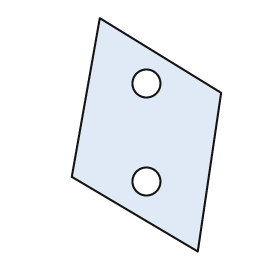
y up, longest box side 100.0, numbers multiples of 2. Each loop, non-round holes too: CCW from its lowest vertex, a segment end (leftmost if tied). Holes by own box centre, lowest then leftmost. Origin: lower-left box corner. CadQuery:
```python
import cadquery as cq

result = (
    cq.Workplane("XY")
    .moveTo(54.0, 0.0)
    .lineTo(64.0, 68.0)
    .lineTo(12.0, 100.0)
    .lineTo(0.0, 32.0)
    .close()
    .moveTo(32.0, 30.0)
    .circle(6.0)
    .moveTo(32.0, 72.0)
    .circle(6.0)
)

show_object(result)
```